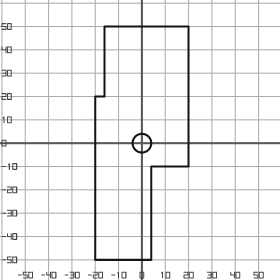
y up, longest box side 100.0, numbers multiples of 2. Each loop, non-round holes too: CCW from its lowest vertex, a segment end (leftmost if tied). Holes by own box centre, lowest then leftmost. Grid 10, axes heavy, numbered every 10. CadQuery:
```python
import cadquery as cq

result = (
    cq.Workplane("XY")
    .moveTo(-20.0, -50.0)
    .lineTo(4.0, -50.0)
    .lineTo(4.0, -10.0)
    .lineTo(20.0, -10.0)
    .lineTo(20.0, 50.0)
    .lineTo(-16.0, 50.0)
    .lineTo(-16.0, 20.0)
    .lineTo(-20.0, 20.0)
    .close()
    .moveTo(0.0, 0.0)
    .circle(4.0)
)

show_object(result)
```